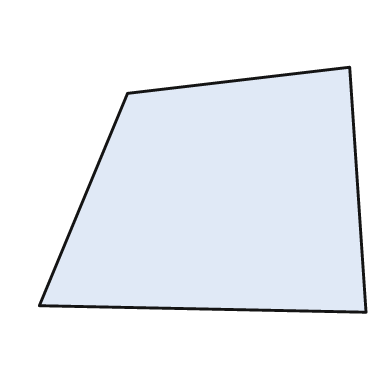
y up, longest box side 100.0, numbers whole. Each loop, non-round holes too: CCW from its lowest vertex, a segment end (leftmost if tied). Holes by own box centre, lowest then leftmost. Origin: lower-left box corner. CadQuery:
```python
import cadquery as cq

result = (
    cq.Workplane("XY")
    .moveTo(100.0, 0.0)
    .lineTo(95.0, 75.0)
    .lineTo(27.0, 67.0)
    .lineTo(0.0, 2.0)
    .close()
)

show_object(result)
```